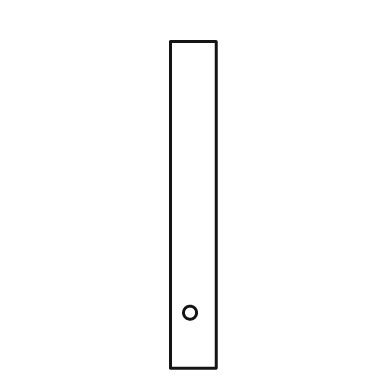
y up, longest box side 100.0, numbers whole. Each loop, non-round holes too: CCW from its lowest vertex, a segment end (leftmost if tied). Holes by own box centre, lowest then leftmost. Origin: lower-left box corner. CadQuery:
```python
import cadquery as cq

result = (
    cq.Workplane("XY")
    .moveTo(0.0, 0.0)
    .lineTo(14.0, 0.0)
    .lineTo(14.0, 100.0)
    .lineTo(0.0, 100.0)
    .close()
    .moveTo(6.0, 17.0)
    .circle(2.0)
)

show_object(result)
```